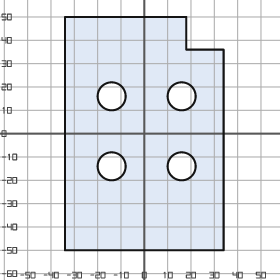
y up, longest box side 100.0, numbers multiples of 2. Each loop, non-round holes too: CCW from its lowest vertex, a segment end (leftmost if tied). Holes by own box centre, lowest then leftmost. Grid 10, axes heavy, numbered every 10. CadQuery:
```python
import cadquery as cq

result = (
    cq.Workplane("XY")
    .moveTo(-34.0, -50.0)
    .lineTo(34.0, -50.0)
    .lineTo(34.0, 36.0)
    .lineTo(18.0, 36.0)
    .lineTo(18.0, 50.0)
    .lineTo(-34.0, 50.0)
    .close()
    .moveTo(-14.0, -14.0)
    .circle(6.0)
    .moveTo(16.0, -14.0)
    .circle(6.0)
    .moveTo(-14.0, 16.0)
    .circle(6.0)
    .moveTo(16.0, 16.0)
    .circle(6.0)
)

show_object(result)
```